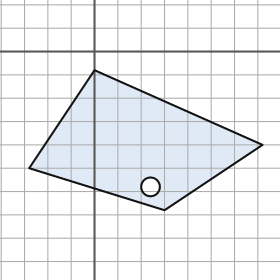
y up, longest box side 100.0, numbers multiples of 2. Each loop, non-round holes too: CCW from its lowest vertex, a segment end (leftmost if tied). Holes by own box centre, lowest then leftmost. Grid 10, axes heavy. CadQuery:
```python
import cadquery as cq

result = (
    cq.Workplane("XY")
    .moveTo(30.0, -68.0)
    .lineTo(72.0, -40.0)
    .lineTo(0.0, -8.0)
    .lineTo(-28.0, -50.0)
    .close()
    .moveTo(24.0, -58.0)
    .circle(4.0)
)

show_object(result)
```